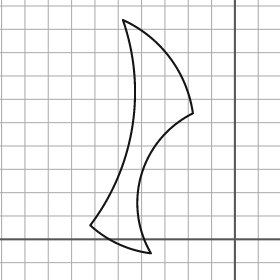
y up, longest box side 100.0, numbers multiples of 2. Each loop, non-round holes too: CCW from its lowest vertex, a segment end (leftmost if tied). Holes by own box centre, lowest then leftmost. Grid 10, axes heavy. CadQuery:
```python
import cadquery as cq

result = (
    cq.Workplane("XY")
    .moveTo(-36.0, -6.0)
    .threePointArc((-40.0, 28.0), (-18.0, 54.0))
    .threePointArc((-28.0, 78.0), (-48.0, 94.0))
    .threePointArc((-44.0, 48.0), (-62.0, 6.0))
    .threePointArc((-50.0, -2.0), (-36.0, -6.0))
    .close()
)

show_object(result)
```